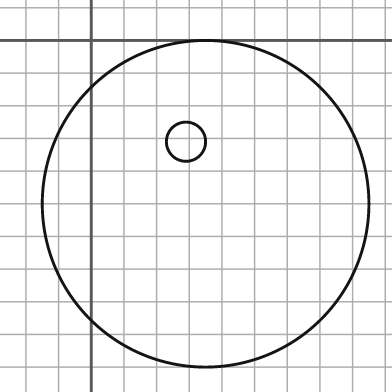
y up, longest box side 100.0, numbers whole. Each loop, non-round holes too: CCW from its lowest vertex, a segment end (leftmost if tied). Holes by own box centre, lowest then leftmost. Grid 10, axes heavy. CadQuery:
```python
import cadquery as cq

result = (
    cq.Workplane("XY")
    .moveTo(35.0, -50.0)
    .circle(50.0)
    .moveTo(29.0, -31.0)
    .circle(6.0)
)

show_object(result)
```